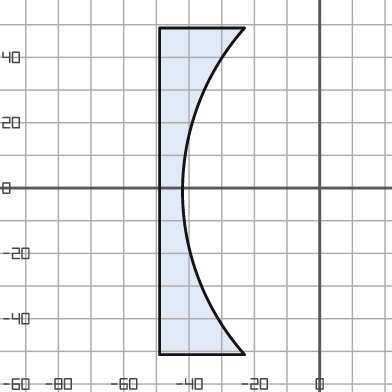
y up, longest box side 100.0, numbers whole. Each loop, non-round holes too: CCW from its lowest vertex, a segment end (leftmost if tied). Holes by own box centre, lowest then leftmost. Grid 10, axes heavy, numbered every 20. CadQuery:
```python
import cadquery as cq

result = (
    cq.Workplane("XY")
    .moveTo(-49.0, -51.0)
    .lineTo(-23.0, -51.0)
    .threePointArc((-42.0, -1.0), (-23.0, 49.0))
    .lineTo(-49.0, 49.0)
    .close()
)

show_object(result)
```